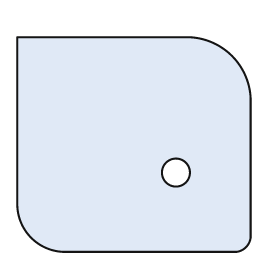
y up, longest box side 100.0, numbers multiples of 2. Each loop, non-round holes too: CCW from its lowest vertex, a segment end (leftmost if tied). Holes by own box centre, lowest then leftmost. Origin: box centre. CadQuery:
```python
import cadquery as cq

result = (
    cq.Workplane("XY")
    .moveTo(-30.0, -46.0)
    .lineTo(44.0, -46.0)
    .threePointArc((48.0, -44.0), (50.0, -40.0))
    .lineTo(50.0, 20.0)
    .threePointArc((42.0, 38.0), (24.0, 46.0))
    .lineTo(-50.0, 46.0)
    .lineTo(-50.0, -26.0)
    .threePointArc((-44.0, -40.0), (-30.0, -46.0))
    .close()
    .moveTo(18.0, -12.0)
    .circle(6.0)
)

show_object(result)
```